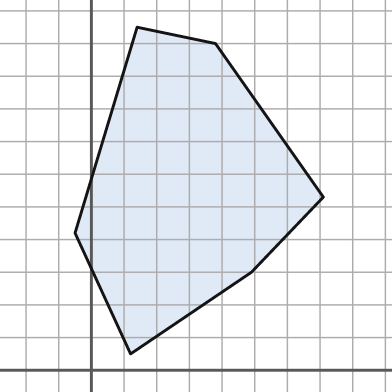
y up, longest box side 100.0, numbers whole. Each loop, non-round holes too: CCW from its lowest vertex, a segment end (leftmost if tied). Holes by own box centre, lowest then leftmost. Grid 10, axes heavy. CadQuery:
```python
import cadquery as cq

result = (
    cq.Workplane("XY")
    .moveTo(12.0, 5.0)
    .lineTo(49.0, 30.0)
    .lineTo(71.0, 53.0)
    .lineTo(38.0, 100.0)
    .lineTo(14.0, 105.0)
    .lineTo(-5.0, 42.0)
    .close()
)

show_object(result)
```